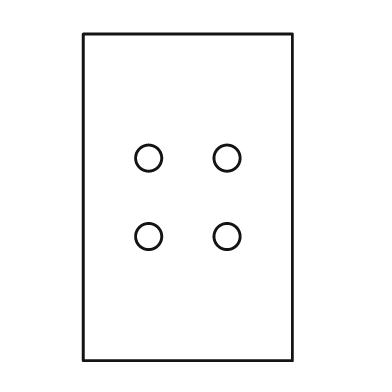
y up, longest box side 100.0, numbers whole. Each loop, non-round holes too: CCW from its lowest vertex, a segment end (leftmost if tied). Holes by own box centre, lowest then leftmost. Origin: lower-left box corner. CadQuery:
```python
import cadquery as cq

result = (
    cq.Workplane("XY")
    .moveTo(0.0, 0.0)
    .lineTo(64.0, 0.0)
    .lineTo(64.0, 100.0)
    .lineTo(0.0, 100.0)
    .close()
    .moveTo(20.0, 38.0)
    .circle(4.0)
    .moveTo(44.0, 38.0)
    .circle(4.0)
    .moveTo(20.0, 62.0)
    .circle(4.0)
    .moveTo(44.0, 62.0)
    .circle(4.0)
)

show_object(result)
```